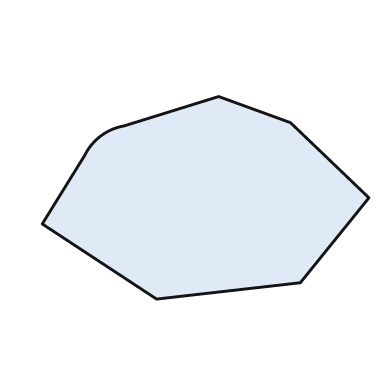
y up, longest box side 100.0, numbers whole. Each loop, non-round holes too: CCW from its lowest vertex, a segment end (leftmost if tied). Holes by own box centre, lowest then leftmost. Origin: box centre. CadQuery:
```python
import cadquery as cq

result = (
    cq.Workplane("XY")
    .moveTo(-15.0, -31.0)
    .lineTo(29.0, -26.0)
    .lineTo(50.0, 0.0)
    .lineTo(26.0, 23.0)
    .lineTo(4.0, 31.0)
    .lineTo(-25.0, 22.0)
    .threePointArc((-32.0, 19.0), (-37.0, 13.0))
    .lineTo(-50.0, -8.0)
    .close()
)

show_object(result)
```